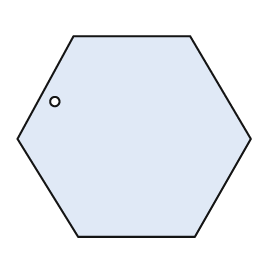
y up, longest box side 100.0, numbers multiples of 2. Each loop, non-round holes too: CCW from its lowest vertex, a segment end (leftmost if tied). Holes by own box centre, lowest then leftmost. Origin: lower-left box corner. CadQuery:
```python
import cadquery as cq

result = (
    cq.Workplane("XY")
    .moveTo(26.0, 0.0)
    .lineTo(76.0, 0.0)
    .lineTo(100.0, 42.0)
    .lineTo(74.0, 86.0)
    .lineTo(24.0, 86.0)
    .lineTo(0.0, 42.0)
    .close()
    .moveTo(16.0, 58.0)
    .circle(2.0)
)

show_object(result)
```